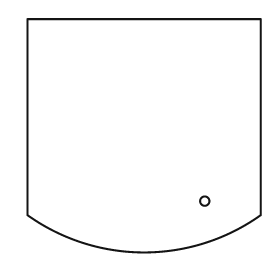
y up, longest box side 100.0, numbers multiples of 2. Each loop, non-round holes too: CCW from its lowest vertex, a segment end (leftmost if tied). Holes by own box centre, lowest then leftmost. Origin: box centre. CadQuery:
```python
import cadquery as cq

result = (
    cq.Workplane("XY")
    .moveTo(-50.0, -34.0)
    .threePointArc((0.0, -50.0), (50.0, -34.0))
    .lineTo(50.0, 50.0)
    .lineTo(-50.0, 50.0)
    .close()
    .moveTo(26.0, -28.0)
    .circle(2.0)
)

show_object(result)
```